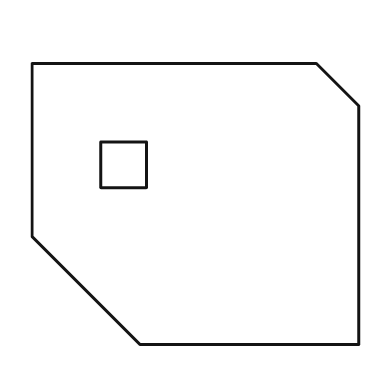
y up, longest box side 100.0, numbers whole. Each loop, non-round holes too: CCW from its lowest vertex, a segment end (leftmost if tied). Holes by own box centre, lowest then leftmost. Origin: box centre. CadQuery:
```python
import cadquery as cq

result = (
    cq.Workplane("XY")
    .moveTo(-17.0, -43.0)
    .lineTo(50.0, -43.0)
    .lineTo(50.0, 30.0)
    .lineTo(37.0, 43.0)
    .lineTo(-50.0, 43.0)
    .lineTo(-50.0, -10.0)
    .close()
    .moveTo(-29.0, 5.0)
    .lineTo(-15.0, 5.0)
    .lineTo(-15.0, 19.0)
    .lineTo(-29.0, 19.0)
    .close()
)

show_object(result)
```